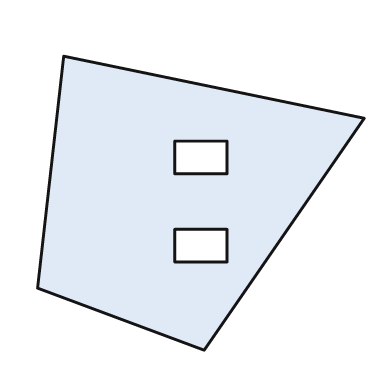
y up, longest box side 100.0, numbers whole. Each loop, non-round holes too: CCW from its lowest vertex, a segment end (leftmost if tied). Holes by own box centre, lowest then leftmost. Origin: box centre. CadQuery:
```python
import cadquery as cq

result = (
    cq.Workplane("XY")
    .moveTo(1.0, -45.0)
    .lineTo(50.0, 26.0)
    .lineTo(-42.0, 45.0)
    .lineTo(-50.0, -26.0)
    .close()
    .moveTo(-8.0, -18.0)
    .lineTo(8.0, -18.0)
    .lineTo(8.0, -8.0)
    .lineTo(-8.0, -8.0)
    .close()
    .moveTo(-8.0, 9.0)
    .lineTo(8.0, 9.0)
    .lineTo(8.0, 19.0)
    .lineTo(-8.0, 19.0)
    .close()
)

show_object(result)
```